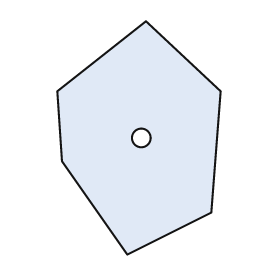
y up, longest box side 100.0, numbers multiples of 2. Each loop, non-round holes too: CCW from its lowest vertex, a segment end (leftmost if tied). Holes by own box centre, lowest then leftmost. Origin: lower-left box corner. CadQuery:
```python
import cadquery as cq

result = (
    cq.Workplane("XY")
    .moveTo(30.0, 0.0)
    .lineTo(66.0, 18.0)
    .lineTo(70.0, 70.0)
    .lineTo(38.0, 100.0)
    .lineTo(0.0, 70.0)
    .lineTo(2.0, 40.0)
    .close()
    .moveTo(36.0, 50.0)
    .circle(4.0)
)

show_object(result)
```